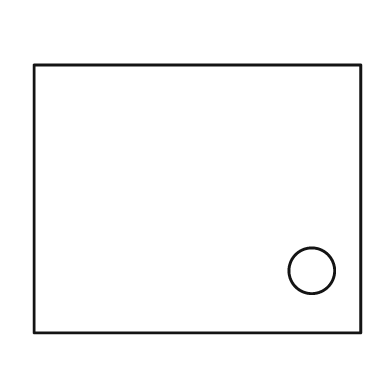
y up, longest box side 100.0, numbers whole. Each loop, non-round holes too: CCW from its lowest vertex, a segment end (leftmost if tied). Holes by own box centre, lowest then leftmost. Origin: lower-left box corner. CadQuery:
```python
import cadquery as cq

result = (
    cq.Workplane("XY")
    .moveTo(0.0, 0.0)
    .lineTo(100.0, 0.0)
    .lineTo(100.0, 82.0)
    .lineTo(0.0, 82.0)
    .close()
    .moveTo(85.0, 19.0)
    .circle(7.0)
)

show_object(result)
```